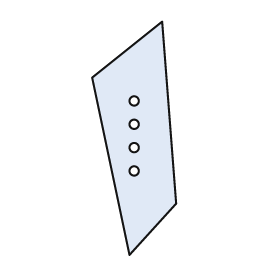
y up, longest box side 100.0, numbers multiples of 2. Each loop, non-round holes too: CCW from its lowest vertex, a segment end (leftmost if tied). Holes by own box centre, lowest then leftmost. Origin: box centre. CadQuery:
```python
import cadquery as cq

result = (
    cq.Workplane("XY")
    .moveTo(-2.0, -50.0)
    .lineTo(18.0, -28.0)
    .lineTo(12.0, 50.0)
    .lineTo(-18.0, 26.0)
    .close()
    .moveTo(0.0, -14.0)
    .circle(2.0)
    .moveTo(0.0, -4.0)
    .circle(2.0)
    .moveTo(0.0, 6.0)
    .circle(2.0)
    .moveTo(0.0, 16.0)
    .circle(2.0)
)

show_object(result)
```